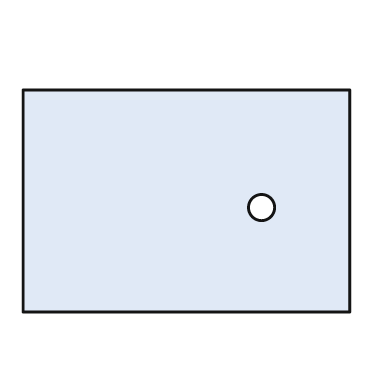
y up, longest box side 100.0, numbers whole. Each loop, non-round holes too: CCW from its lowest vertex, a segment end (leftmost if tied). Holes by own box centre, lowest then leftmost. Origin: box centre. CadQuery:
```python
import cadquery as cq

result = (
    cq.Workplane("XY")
    .moveTo(-50.0, -34.0)
    .lineTo(50.0, -34.0)
    .lineTo(50.0, 34.0)
    .lineTo(-50.0, 34.0)
    .close()
    .moveTo(23.0, -2.0)
    .circle(4.0)
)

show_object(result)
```